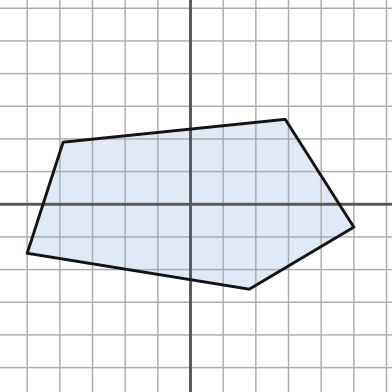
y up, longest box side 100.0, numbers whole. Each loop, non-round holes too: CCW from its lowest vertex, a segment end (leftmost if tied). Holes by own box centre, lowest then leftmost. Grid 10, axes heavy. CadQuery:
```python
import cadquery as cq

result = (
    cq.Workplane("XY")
    .moveTo(18.0, -26.0)
    .lineTo(50.0, -7.0)
    .lineTo(29.0, 26.0)
    .lineTo(-39.0, 19.0)
    .lineTo(-50.0, -15.0)
    .close()
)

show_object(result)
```